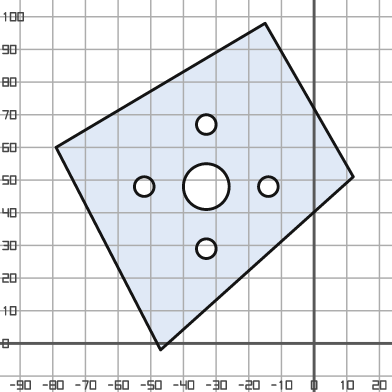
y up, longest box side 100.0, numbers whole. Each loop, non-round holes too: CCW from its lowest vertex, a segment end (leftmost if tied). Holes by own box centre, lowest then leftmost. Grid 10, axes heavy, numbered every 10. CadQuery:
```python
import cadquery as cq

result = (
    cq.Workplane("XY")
    .moveTo(-47.0, -2.0)
    .lineTo(12.0, 51.0)
    .lineTo(-15.0, 98.0)
    .lineTo(-79.0, 60.0)
    .close()
    .moveTo(-33.0, 29.0)
    .circle(3.0)
    .moveTo(-52.0, 48.0)
    .circle(3.0)
    .moveTo(-33.0, 48.0)
    .circle(7.0)
    .moveTo(-14.0, 48.0)
    .circle(3.0)
    .moveTo(-33.0, 67.0)
    .circle(3.0)
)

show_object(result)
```